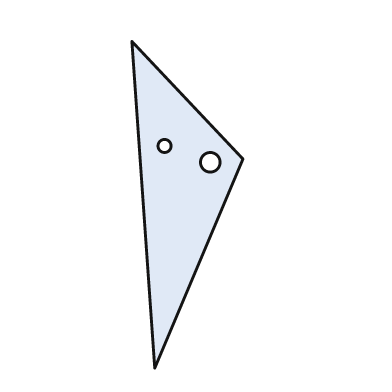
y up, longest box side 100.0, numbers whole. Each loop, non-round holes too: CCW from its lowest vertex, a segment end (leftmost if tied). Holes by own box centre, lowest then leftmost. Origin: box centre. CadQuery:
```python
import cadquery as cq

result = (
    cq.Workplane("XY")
    .moveTo(-10.0, -50.0)
    .lineTo(17.0, 14.0)
    .lineTo(-17.0, 50.0)
    .close()
    .moveTo(7.0, 13.0)
    .circle(3.0)
    .moveTo(-7.0, 18.0)
    .circle(2.0)
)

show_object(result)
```